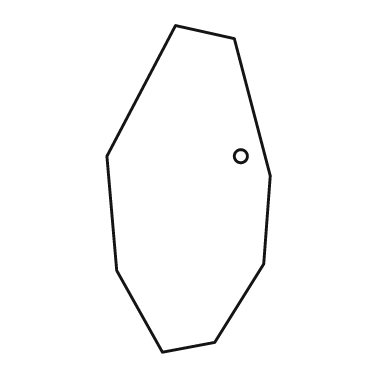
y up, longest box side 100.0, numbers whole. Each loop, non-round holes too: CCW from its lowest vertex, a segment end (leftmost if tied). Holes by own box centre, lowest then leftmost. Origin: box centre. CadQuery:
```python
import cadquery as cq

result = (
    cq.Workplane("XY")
    .moveTo(-8.0, -50.0)
    .lineTo(8.0, -47.0)
    .lineTo(23.0, -23.0)
    .lineTo(25.0, 4.0)
    .lineTo(14.0, 46.0)
    .lineTo(-4.0, 50.0)
    .lineTo(-25.0, 10.0)
    .lineTo(-22.0, -25.0)
    .close()
    .moveTo(16.0, 10.0)
    .circle(2.0)
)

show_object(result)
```